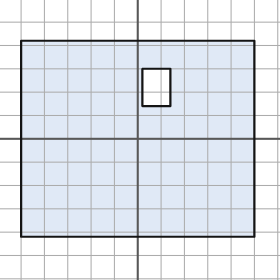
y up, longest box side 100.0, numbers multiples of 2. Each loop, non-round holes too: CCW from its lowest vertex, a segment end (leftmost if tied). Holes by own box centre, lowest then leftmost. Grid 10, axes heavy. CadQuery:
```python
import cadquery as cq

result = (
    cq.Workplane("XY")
    .moveTo(-50.0, -42.0)
    .lineTo(50.0, -42.0)
    .lineTo(50.0, 42.0)
    .lineTo(-50.0, 42.0)
    .close()
    .moveTo(2.0, 14.0)
    .lineTo(14.0, 14.0)
    .lineTo(14.0, 30.0)
    .lineTo(2.0, 30.0)
    .close()
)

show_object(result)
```